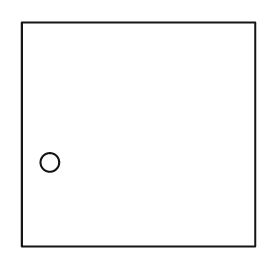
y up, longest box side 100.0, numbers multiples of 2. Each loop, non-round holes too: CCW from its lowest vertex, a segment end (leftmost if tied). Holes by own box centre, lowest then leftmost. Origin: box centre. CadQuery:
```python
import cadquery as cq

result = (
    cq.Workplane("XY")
    .moveTo(-50.0, -48.0)
    .lineTo(50.0, -48.0)
    .lineTo(50.0, 48.0)
    .lineTo(-50.0, 48.0)
    .close()
    .moveTo(-38.0, -12.0)
    .circle(4.0)
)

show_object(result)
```